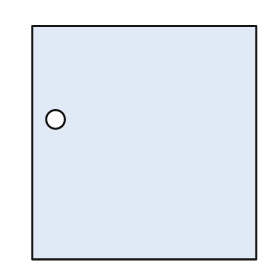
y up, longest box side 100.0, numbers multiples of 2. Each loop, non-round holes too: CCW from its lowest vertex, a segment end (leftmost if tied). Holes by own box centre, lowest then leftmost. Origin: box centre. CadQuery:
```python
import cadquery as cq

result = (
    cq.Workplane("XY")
    .moveTo(-48.0, -50.0)
    .lineTo(48.0, -50.0)
    .lineTo(48.0, 50.0)
    .lineTo(-48.0, 50.0)
    .close()
    .moveTo(-38.0, 10.0)
    .circle(4.0)
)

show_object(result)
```